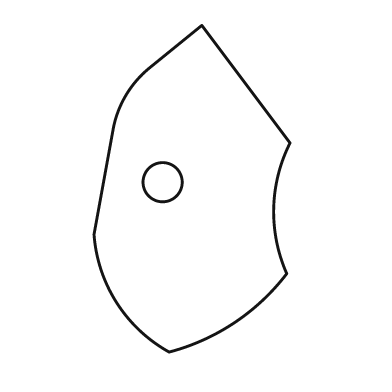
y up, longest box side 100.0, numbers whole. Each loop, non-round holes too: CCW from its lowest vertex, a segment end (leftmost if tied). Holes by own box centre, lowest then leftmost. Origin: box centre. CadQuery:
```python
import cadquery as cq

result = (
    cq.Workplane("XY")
    .moveTo(-7.0, -50.0)
    .threePointArc((13.0, -41.0), (29.0, -26.0))
    .threePointArc((25.0, -6.0), (30.0, 14.0))
    .lineTo(3.0, 50.0)
    .lineTo(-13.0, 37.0)
    .threePointArc((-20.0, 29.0), (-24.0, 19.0))
    .lineTo(-30.0, -14.0)
    .threePointArc((-23.0, -35.0), (-7.0, -50.0))
    .close()
    .moveTo(-9.0, 2.0)
    .circle(6.0)
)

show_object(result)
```